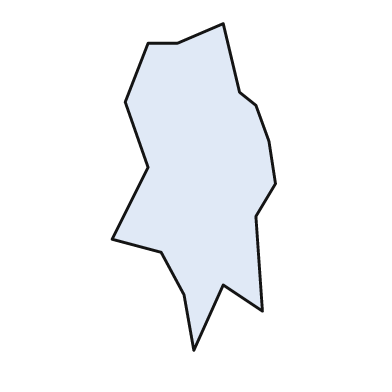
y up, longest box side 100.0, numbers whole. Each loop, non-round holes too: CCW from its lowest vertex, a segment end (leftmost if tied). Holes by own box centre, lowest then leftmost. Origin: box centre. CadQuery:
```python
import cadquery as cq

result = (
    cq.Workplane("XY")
    .moveTo(0.0, -50.0)
    .lineTo(9.0, -30.0)
    .lineTo(21.0, -38.0)
    .lineTo(19.0, -9.0)
    .lineTo(25.0, 1.0)
    .lineTo(23.0, 14.0)
    .lineTo(19.0, 25.0)
    .lineTo(14.0, 29.0)
    .lineTo(9.0, 50.0)
    .lineTo(-5.0, 44.0)
    .lineTo(-14.0, 44.0)
    .lineTo(-21.0, 26.0)
    .lineTo(-14.0, 6.0)
    .lineTo(-25.0, -16.0)
    .lineTo(-10.0, -20.0)
    .lineTo(-3.0, -33.0)
    .close()
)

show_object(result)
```